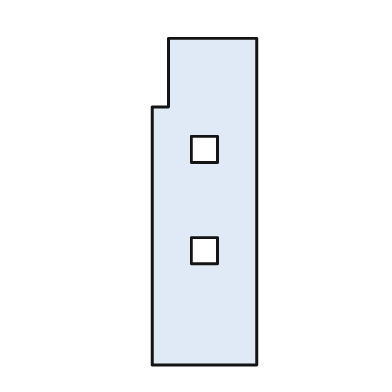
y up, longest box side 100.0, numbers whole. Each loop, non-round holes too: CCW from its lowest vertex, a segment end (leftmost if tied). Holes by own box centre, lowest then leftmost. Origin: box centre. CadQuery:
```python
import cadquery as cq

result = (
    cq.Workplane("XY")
    .moveTo(-16.0, -50.0)
    .lineTo(16.0, -50.0)
    .lineTo(16.0, 50.0)
    .lineTo(-11.0, 50.0)
    .lineTo(-11.0, 29.0)
    .lineTo(-16.0, 29.0)
    .close()
    .moveTo(-4.0, -19.0)
    .lineTo(4.0, -19.0)
    .lineTo(4.0, -11.0)
    .lineTo(-4.0, -11.0)
    .close()
    .moveTo(-4.0, 12.0)
    .lineTo(4.0, 12.0)
    .lineTo(4.0, 20.0)
    .lineTo(-4.0, 20.0)
    .close()
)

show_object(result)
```